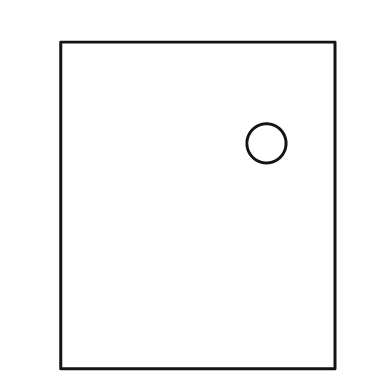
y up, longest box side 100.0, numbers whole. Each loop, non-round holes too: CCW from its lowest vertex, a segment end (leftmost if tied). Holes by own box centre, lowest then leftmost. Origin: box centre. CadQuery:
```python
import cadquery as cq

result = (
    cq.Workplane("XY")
    .moveTo(-42.0, -50.0)
    .lineTo(42.0, -50.0)
    .lineTo(42.0, 50.0)
    .lineTo(-42.0, 50.0)
    .close()
    .moveTo(21.0, 19.0)
    .circle(6.0)
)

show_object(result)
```